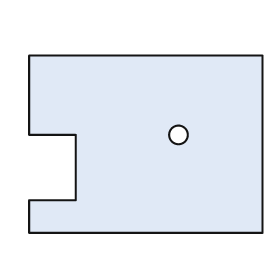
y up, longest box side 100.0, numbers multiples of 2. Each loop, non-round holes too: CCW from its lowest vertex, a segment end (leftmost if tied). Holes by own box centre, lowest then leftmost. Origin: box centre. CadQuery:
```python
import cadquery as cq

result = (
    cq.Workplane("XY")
    .moveTo(-50.0, -38.0)
    .lineTo(50.0, -38.0)
    .lineTo(50.0, 38.0)
    .lineTo(-50.0, 38.0)
    .lineTo(-50.0, 4.0)
    .lineTo(-30.0, 4.0)
    .lineTo(-30.0, -24.0)
    .lineTo(-50.0, -24.0)
    .close()
    .moveTo(14.0, 4.0)
    .circle(4.0)
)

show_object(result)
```